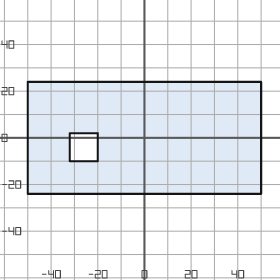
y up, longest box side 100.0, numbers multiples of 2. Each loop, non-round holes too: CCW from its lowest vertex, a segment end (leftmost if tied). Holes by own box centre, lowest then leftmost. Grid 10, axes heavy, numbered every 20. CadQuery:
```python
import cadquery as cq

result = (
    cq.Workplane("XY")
    .moveTo(-50.0, -24.0)
    .lineTo(50.0, -24.0)
    .lineTo(50.0, 24.0)
    .lineTo(-50.0, 24.0)
    .close()
    .moveTo(-32.0, -10.0)
    .lineTo(-20.0, -10.0)
    .lineTo(-20.0, 2.0)
    .lineTo(-32.0, 2.0)
    .close()
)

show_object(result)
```